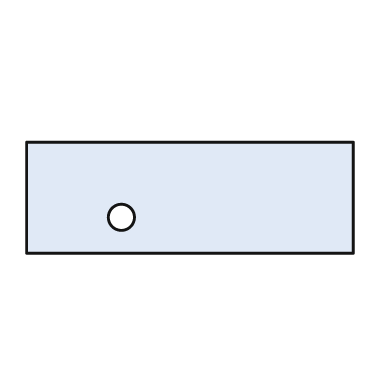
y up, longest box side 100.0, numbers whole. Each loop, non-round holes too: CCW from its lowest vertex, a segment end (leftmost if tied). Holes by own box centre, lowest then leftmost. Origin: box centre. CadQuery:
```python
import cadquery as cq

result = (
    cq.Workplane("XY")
    .moveTo(-50.0, -17.0)
    .lineTo(50.0, -17.0)
    .lineTo(50.0, 17.0)
    .lineTo(-50.0, 17.0)
    .close()
    .moveTo(-21.0, -6.0)
    .circle(4.0)
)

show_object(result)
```